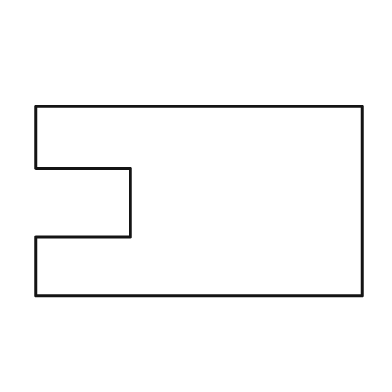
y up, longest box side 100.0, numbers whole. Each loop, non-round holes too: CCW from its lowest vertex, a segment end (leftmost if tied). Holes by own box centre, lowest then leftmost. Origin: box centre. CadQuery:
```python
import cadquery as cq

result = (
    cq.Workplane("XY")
    .moveTo(-50.0, -29.0)
    .lineTo(50.0, -29.0)
    .lineTo(50.0, 29.0)
    .lineTo(-50.0, 29.0)
    .lineTo(-50.0, 10.0)
    .lineTo(-21.0, 10.0)
    .lineTo(-21.0, -11.0)
    .lineTo(-50.0, -11.0)
    .close()
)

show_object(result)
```